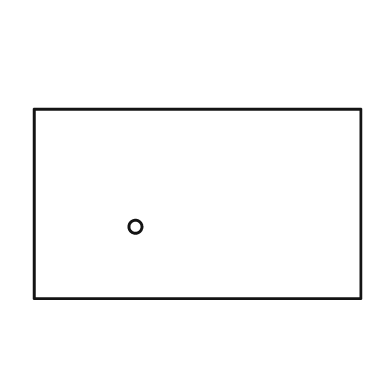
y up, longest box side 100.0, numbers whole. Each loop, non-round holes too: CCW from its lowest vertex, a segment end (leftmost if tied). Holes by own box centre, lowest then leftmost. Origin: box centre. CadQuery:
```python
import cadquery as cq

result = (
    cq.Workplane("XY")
    .moveTo(-50.0, -29.0)
    .lineTo(50.0, -29.0)
    .lineTo(50.0, 29.0)
    .lineTo(-50.0, 29.0)
    .close()
    .moveTo(-19.0, -7.0)
    .circle(2.0)
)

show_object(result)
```